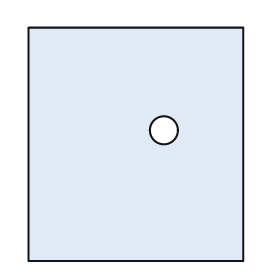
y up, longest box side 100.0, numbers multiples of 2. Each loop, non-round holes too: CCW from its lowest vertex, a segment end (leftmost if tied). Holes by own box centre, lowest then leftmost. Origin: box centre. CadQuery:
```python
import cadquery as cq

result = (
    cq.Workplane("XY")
    .moveTo(-46.0, -50.0)
    .lineTo(46.0, -50.0)
    .lineTo(46.0, 50.0)
    .lineTo(-46.0, 50.0)
    .close()
    .moveTo(12.0, 6.0)
    .circle(6.0)
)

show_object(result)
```